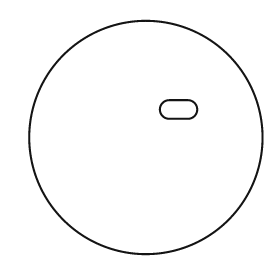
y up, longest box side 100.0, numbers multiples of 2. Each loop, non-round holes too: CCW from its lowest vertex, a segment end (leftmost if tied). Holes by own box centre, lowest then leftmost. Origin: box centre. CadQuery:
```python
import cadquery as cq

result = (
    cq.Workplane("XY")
    .moveTo(0.0, 0.0)
    .circle(50.0)
    .moveTo(10.0, 8.0)
    .lineTo(18.0, 8.0)
    .threePointArc((22.0, 12.0), (18.0, 16.0))
    .lineTo(10.0, 16.0)
    .threePointArc((6.0, 12.0), (10.0, 8.0))
    .close()
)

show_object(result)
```